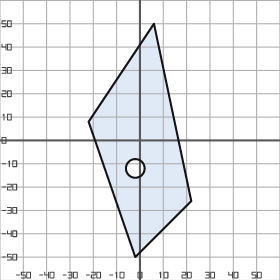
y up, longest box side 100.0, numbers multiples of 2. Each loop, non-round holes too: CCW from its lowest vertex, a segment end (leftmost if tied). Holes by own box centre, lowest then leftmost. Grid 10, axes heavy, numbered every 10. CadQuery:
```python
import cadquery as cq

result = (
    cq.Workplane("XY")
    .moveTo(-2.0, -50.0)
    .lineTo(22.0, -26.0)
    .lineTo(6.0, 50.0)
    .lineTo(-22.0, 8.0)
    .close()
    .moveTo(-2.0, -12.0)
    .circle(4.0)
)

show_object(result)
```